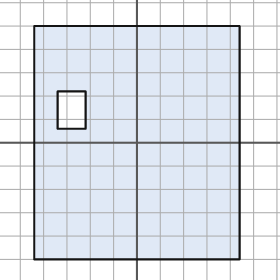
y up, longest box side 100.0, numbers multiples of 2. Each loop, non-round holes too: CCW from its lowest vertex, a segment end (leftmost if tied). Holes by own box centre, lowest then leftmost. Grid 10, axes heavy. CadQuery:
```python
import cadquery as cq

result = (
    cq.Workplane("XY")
    .moveTo(-44.0, -50.0)
    .lineTo(44.0, -50.0)
    .lineTo(44.0, 50.0)
    .lineTo(-44.0, 50.0)
    .close()
    .moveTo(-34.0, 6.0)
    .lineTo(-22.0, 6.0)
    .lineTo(-22.0, 22.0)
    .lineTo(-34.0, 22.0)
    .close()
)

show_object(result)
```